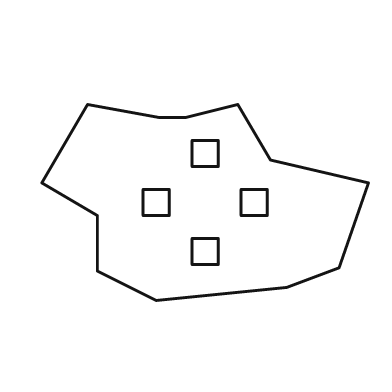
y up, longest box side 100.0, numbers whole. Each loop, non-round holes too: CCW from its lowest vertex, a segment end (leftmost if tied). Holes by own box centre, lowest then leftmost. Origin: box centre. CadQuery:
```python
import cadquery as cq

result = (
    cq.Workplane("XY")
    .moveTo(-15.0, -30.0)
    .lineTo(25.0, -26.0)
    .lineTo(41.0, -20.0)
    .lineTo(50.0, 6.0)
    .lineTo(20.0, 13.0)
    .lineTo(10.0, 30.0)
    .lineTo(-6.0, 26.0)
    .lineTo(-14.0, 26.0)
    .lineTo(-36.0, 30.0)
    .lineTo(-50.0, 6.0)
    .lineTo(-33.0, -4.0)
    .lineTo(-33.0, -21.0)
    .close()
    .moveTo(-4.0, -19.0)
    .lineTo(4.0, -19.0)
    .lineTo(4.0, -11.0)
    .lineTo(-4.0, -11.0)
    .close()
    .moveTo(-19.0, -4.0)
    .lineTo(-11.0, -4.0)
    .lineTo(-11.0, 4.0)
    .lineTo(-19.0, 4.0)
    .close()
    .moveTo(11.0, -4.0)
    .lineTo(19.0, -4.0)
    .lineTo(19.0, 4.0)
    .lineTo(11.0, 4.0)
    .close()
    .moveTo(-4.0, 11.0)
    .lineTo(4.0, 11.0)
    .lineTo(4.0, 19.0)
    .lineTo(-4.0, 19.0)
    .close()
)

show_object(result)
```